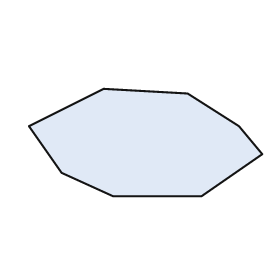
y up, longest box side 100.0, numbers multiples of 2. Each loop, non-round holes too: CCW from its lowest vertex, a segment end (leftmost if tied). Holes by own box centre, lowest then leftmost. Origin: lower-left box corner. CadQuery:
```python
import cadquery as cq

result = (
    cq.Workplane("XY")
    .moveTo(36.0, 0.0)
    .lineTo(74.0, 0.0)
    .lineTo(100.0, 18.0)
    .lineTo(90.0, 30.0)
    .lineTo(68.0, 44.0)
    .lineTo(32.0, 46.0)
    .lineTo(0.0, 30.0)
    .lineTo(14.0, 10.0)
    .close()
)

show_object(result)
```